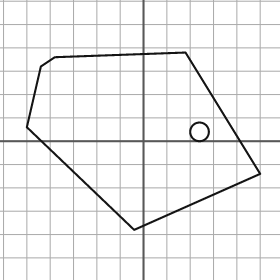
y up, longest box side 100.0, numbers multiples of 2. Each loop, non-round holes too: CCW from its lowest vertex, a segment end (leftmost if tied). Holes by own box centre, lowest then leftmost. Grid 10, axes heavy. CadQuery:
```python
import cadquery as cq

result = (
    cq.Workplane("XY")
    .moveTo(-4.0, -38.0)
    .lineTo(50.0, -14.0)
    .lineTo(18.0, 38.0)
    .lineTo(-38.0, 36.0)
    .lineTo(-44.0, 32.0)
    .lineTo(-50.0, 6.0)
    .close()
    .moveTo(24.0, 4.0)
    .circle(4.0)
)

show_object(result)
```